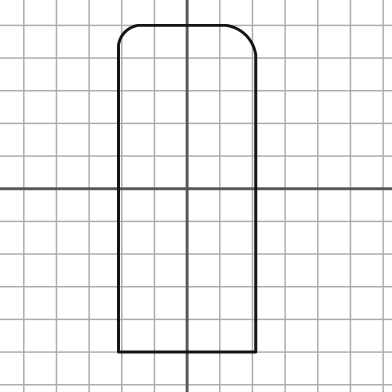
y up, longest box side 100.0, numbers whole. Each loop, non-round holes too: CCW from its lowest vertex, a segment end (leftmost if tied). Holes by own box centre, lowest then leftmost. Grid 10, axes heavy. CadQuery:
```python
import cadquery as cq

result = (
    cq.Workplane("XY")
    .moveTo(-21.0, -50.0)
    .lineTo(21.0, -50.0)
    .lineTo(21.0, 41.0)
    .threePointArc((18.0, 47.0), (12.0, 50.0))
    .lineTo(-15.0, 50.0)
    .threePointArc((-19.0, 48.0), (-21.0, 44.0))
    .close()
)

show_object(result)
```